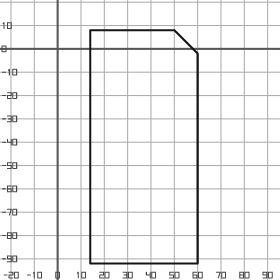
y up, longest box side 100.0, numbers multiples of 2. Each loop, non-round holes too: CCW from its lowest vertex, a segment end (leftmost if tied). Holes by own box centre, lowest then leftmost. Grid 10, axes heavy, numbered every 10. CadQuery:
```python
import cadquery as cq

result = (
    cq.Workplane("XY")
    .moveTo(14.0, -92.0)
    .lineTo(60.0, -92.0)
    .lineTo(60.0, -2.0)
    .lineTo(50.0, 8.0)
    .lineTo(14.0, 8.0)
    .close()
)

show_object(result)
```